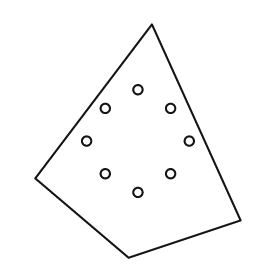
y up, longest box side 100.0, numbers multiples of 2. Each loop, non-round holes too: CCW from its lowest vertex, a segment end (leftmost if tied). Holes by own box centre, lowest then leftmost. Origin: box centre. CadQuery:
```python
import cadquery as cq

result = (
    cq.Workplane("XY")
    .moveTo(-4.0, -50.0)
    .lineTo(44.0, -34.0)
    .lineTo(6.0, 50.0)
    .lineTo(-44.0, -16.0)
    .close()
    .moveTo(0.0, -22.0)
    .circle(2.0)
    .moveTo(-14.0, -14.0)
    .circle(2.0)
    .moveTo(14.0, -14.0)
    .circle(2.0)
    .moveTo(-22.0, 0.0)
    .circle(2.0)
    .moveTo(22.0, 0.0)
    .circle(2.0)
    .moveTo(-14.0, 14.0)
    .circle(2.0)
    .moveTo(14.0, 14.0)
    .circle(2.0)
    .moveTo(0.0, 22.0)
    .circle(2.0)
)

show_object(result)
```